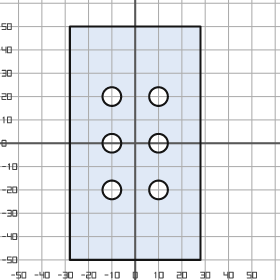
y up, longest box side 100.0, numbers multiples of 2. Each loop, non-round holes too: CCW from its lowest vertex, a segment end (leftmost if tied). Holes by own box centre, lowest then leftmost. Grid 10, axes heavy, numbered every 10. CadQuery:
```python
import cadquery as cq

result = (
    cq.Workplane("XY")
    .moveTo(-28.0, -50.0)
    .lineTo(28.0, -50.0)
    .lineTo(28.0, 50.0)
    .lineTo(-28.0, 50.0)
    .close()
    .moveTo(-10.0, -20.0)
    .circle(4.0)
    .moveTo(10.0, -20.0)
    .circle(4.0)
    .moveTo(-10.0, 0.0)
    .circle(4.0)
    .moveTo(10.0, 0.0)
    .circle(4.0)
    .moveTo(-10.0, 20.0)
    .circle(4.0)
    .moveTo(10.0, 20.0)
    .circle(4.0)
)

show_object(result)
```